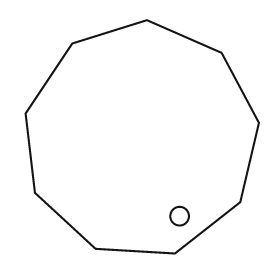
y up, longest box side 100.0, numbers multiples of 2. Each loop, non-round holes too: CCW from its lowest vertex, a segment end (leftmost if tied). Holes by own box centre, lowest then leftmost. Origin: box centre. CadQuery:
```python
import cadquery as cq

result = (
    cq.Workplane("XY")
    .moveTo(14.0, -50.0)
    .lineTo(42.0, -28.0)
    .lineTo(50.0, 6.0)
    .lineTo(34.0, 36.0)
    .lineTo(2.0, 50.0)
    .lineTo(-30.0, 40.0)
    .lineTo(-50.0, 10.0)
    .lineTo(-46.0, -24.0)
    .lineTo(-20.0, -48.0)
    .close()
    .moveTo(16.0, -34.0)
    .circle(4.0)
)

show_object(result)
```